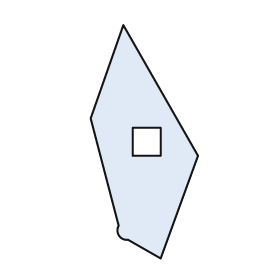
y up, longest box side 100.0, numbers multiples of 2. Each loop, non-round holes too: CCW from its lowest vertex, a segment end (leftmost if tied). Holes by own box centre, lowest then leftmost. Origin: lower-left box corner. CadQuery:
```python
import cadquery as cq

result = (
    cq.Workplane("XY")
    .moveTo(30.0, 0.0)
    .lineTo(46.0, 44.0)
    .lineTo(14.0, 100.0)
    .lineTo(0.0, 60.0)
    .lineTo(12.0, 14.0)
    .threePointArc((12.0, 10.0), (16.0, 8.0))
    .close()
    .moveTo(18.0, 44.0)
    .lineTo(30.0, 44.0)
    .lineTo(30.0, 56.0)
    .lineTo(18.0, 56.0)
    .close()
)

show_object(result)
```